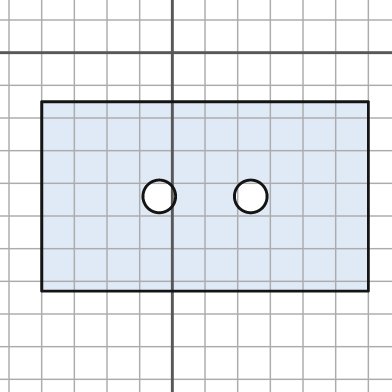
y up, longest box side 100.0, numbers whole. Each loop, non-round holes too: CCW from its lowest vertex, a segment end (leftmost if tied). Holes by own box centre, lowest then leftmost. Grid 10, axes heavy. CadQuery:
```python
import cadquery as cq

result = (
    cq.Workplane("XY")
    .moveTo(-40.0, -73.0)
    .lineTo(60.0, -73.0)
    .lineTo(60.0, -15.0)
    .lineTo(-40.0, -15.0)
    .close()
    .moveTo(-4.0, -44.0)
    .circle(5.0)
    .moveTo(24.0, -44.0)
    .circle(5.0)
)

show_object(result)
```